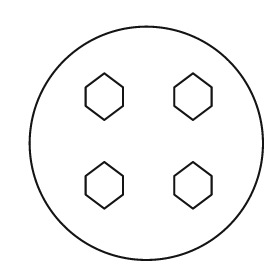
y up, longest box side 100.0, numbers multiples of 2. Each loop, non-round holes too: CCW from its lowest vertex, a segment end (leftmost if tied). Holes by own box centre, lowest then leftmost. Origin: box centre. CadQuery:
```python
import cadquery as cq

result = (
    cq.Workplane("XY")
    .moveTo(0.0, 0.0)
    .circle(50.0)
    .moveTo(-18.0, -28.0)
    .lineTo(-10.0, -22.0)
    .lineTo(-10.0, -14.0)
    .lineTo(-18.0, -8.0)
    .lineTo(-26.0, -14.0)
    .lineTo(-26.0, -22.0)
    .close()
    .moveTo(20.0, -28.0)
    .lineTo(28.0, -22.0)
    .lineTo(28.0, -14.0)
    .lineTo(20.0, -8.0)
    .lineTo(12.0, -14.0)
    .lineTo(12.0, -22.0)
    .close()
    .moveTo(-18.0, 10.0)
    .lineTo(-10.0, 16.0)
    .lineTo(-10.0, 24.0)
    .lineTo(-18.0, 30.0)
    .lineTo(-26.0, 24.0)
    .lineTo(-26.0, 16.0)
    .close()
    .moveTo(20.0, 10.0)
    .lineTo(28.0, 16.0)
    .lineTo(28.0, 24.0)
    .lineTo(20.0, 30.0)
    .lineTo(12.0, 24.0)
    .lineTo(12.0, 16.0)
    .close()
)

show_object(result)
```